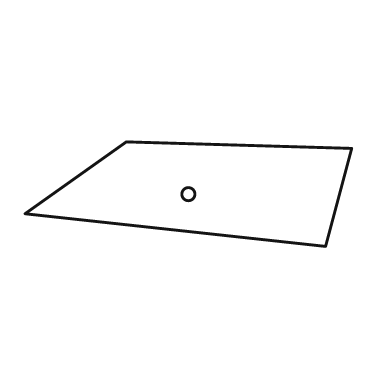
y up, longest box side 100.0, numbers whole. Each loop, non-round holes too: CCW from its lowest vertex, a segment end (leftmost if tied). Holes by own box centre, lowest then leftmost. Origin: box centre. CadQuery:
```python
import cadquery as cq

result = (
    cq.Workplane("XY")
    .moveTo(42.0, -16.0)
    .lineTo(50.0, 14.0)
    .lineTo(-19.0, 16.0)
    .lineTo(-50.0, -6.0)
    .close()
    .moveTo(0.0, 0.0)
    .circle(2.0)
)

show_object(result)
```